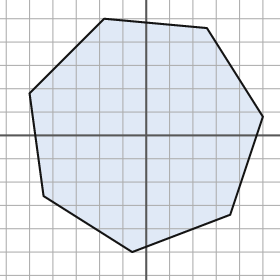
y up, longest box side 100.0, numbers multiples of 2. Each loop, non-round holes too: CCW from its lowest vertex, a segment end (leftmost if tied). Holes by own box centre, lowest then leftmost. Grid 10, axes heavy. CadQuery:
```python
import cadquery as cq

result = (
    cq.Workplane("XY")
    .moveTo(-6.0, -50.0)
    .lineTo(36.0, -34.0)
    .lineTo(50.0, 8.0)
    .lineTo(26.0, 46.0)
    .lineTo(-18.0, 50.0)
    .lineTo(-50.0, 18.0)
    .lineTo(-44.0, -26.0)
    .close()
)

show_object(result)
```